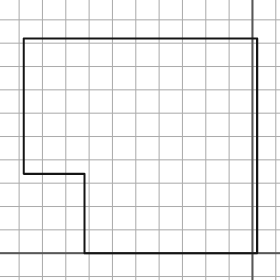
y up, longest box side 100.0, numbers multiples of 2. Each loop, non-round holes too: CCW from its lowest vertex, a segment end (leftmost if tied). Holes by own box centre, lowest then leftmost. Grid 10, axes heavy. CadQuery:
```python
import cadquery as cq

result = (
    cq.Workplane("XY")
    .moveTo(-72.0, 0.0)
    .lineTo(2.0, 0.0)
    .lineTo(2.0, 92.0)
    .lineTo(-98.0, 92.0)
    .lineTo(-98.0, 34.0)
    .lineTo(-72.0, 34.0)
    .close()
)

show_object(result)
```